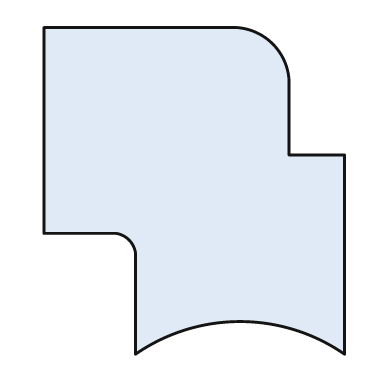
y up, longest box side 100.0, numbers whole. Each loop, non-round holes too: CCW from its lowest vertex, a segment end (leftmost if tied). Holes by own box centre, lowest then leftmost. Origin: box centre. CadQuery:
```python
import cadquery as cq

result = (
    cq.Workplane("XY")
    .moveTo(-18.0, -50.0)
    .threePointArc((14.0, -40.0), (46.0, -50.0))
    .lineTo(46.0, 11.0)
    .lineTo(29.0, 11.0)
    .lineTo(29.0, 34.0)
    .threePointArc((24.0, 45.0), (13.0, 50.0))
    .lineTo(-46.0, 50.0)
    .lineTo(-46.0, -13.0)
    .lineTo(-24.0, -13.0)
    .threePointArc((-20.0, -15.0), (-18.0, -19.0))
    .close()
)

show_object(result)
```